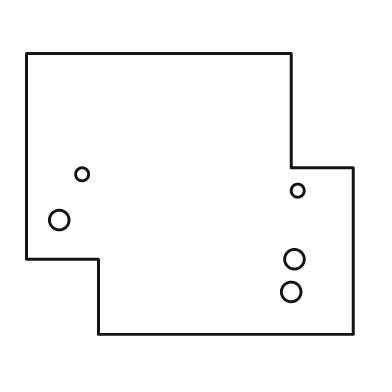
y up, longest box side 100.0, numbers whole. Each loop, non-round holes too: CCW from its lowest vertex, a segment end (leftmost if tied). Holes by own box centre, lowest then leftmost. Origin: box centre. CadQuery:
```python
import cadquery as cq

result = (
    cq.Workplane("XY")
    .moveTo(-28.0, -43.0)
    .lineTo(50.0, -43.0)
    .lineTo(50.0, 8.0)
    .lineTo(31.0, 8.0)
    .lineTo(31.0, 43.0)
    .lineTo(-50.0, 43.0)
    .lineTo(-50.0, -20.0)
    .lineTo(-28.0, -20.0)
    .close()
    .moveTo(31.0, -30.0)
    .circle(3.0)
    .moveTo(32.0, -20.0)
    .circle(3.0)
    .moveTo(-40.0, -8.0)
    .circle(3.0)
    .moveTo(33.0, 1.0)
    .circle(2.0)
    .moveTo(-33.0, 6.0)
    .circle(2.0)
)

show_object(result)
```